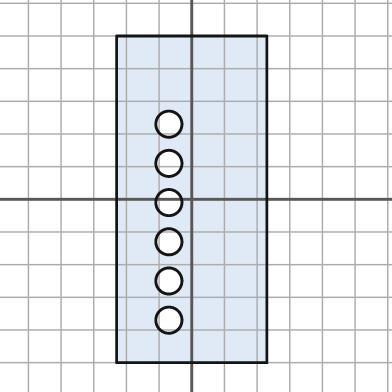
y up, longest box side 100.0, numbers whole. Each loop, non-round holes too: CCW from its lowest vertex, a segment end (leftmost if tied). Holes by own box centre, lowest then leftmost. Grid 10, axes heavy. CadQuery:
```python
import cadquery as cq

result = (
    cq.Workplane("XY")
    .moveTo(-23.0, -50.0)
    .lineTo(23.0, -50.0)
    .lineTo(23.0, 50.0)
    .lineTo(-23.0, 50.0)
    .close()
    .moveTo(-7.0, -37.0)
    .circle(4.0)
    .moveTo(-7.0, -25.0)
    .circle(4.0)
    .moveTo(-7.0, -13.0)
    .circle(4.0)
    .moveTo(-7.0, -1.0)
    .circle(4.0)
    .moveTo(-7.0, 11.0)
    .circle(4.0)
    .moveTo(-7.0, 23.0)
    .circle(4.0)
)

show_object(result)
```